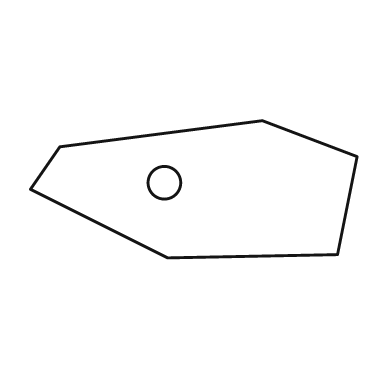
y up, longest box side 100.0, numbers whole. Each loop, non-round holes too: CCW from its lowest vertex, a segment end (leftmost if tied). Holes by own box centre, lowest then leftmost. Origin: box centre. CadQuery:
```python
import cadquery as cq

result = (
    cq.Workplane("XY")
    .moveTo(-8.0, -21.0)
    .lineTo(44.0, -20.0)
    .lineTo(50.0, 10.0)
    .lineTo(21.0, 21.0)
    .lineTo(-41.0, 13.0)
    .lineTo(-50.0, 0.0)
    .close()
    .moveTo(-9.0, 2.0)
    .circle(5.0)
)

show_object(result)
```